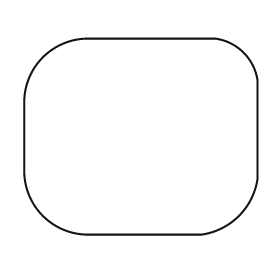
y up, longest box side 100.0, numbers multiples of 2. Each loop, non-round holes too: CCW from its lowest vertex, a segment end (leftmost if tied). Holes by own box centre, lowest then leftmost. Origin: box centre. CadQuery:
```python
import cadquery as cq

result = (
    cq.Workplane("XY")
    .moveTo(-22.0, -42.0)
    .lineTo(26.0, -42.0)
    .threePointArc((42.0, -34.0), (50.0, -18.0))
    .lineTo(50.0, 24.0)
    .threePointArc((44.0, 36.0), (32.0, 42.0))
    .lineTo(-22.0, 42.0)
    .threePointArc((-42.0, 34.0), (-50.0, 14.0))
    .lineTo(-50.0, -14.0)
    .threePointArc((-42.0, -34.0), (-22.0, -42.0))
    .close()
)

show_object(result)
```